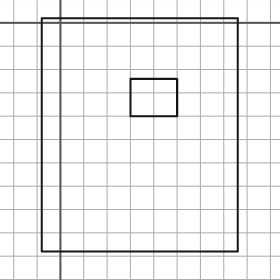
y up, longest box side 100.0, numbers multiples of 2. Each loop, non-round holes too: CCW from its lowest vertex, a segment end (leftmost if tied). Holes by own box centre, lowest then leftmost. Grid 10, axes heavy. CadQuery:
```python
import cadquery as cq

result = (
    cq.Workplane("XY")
    .moveTo(-8.0, -98.0)
    .lineTo(76.0, -98.0)
    .lineTo(76.0, 2.0)
    .lineTo(-8.0, 2.0)
    .close()
    .moveTo(30.0, -40.0)
    .lineTo(50.0, -40.0)
    .lineTo(50.0, -24.0)
    .lineTo(30.0, -24.0)
    .close()
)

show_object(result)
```